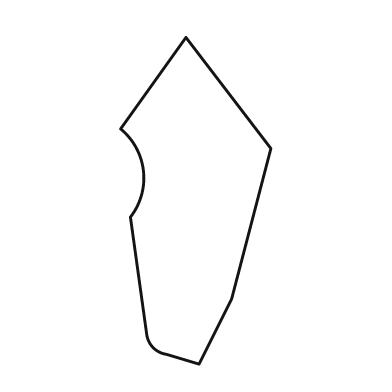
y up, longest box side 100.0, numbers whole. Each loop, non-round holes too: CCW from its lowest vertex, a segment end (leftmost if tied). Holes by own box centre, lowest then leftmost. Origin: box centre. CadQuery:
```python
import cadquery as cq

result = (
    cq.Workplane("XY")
    .moveTo(1.0, -50.0)
    .lineTo(11.0, -30.0)
    .lineTo(23.0, 16.0)
    .lineTo(-3.0, 50.0)
    .lineTo(-23.0, 22.0)
    .threePointArc((-16.0, 9.0), (-20.0, -5.0))
    .lineTo(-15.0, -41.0)
    .threePointArc((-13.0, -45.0), (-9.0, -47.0))
    .close()
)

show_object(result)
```